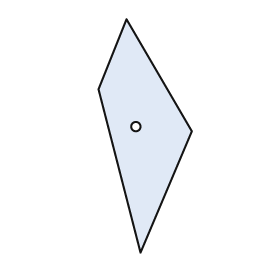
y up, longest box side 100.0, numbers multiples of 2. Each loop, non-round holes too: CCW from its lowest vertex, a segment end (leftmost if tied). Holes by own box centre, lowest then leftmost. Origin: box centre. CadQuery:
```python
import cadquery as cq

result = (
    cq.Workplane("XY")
    .moveTo(-2.0, -50.0)
    .lineTo(20.0, 2.0)
    .lineTo(-8.0, 50.0)
    .lineTo(-20.0, 20.0)
    .close()
    .moveTo(-4.0, 4.0)
    .circle(2.0)
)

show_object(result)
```